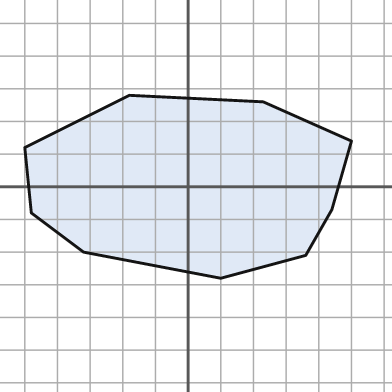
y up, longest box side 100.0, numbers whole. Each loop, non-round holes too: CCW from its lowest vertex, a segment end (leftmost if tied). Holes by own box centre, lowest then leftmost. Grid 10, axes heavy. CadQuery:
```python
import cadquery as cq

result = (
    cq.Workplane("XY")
    .moveTo(10.0, -28.0)
    .lineTo(36.0, -21.0)
    .lineTo(44.0, -7.0)
    .lineTo(50.0, 14.0)
    .lineTo(23.0, 26.0)
    .lineTo(-18.0, 28.0)
    .lineTo(-50.0, 12.0)
    .lineTo(-48.0, -8.0)
    .lineTo(-32.0, -20.0)
    .close()
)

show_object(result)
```